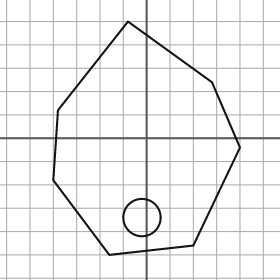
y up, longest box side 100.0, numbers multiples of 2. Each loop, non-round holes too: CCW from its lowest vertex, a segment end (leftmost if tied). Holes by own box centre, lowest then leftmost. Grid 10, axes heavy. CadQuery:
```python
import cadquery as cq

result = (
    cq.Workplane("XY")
    .moveTo(-16.0, -50.0)
    .lineTo(20.0, -46.0)
    .lineTo(40.0, -4.0)
    .lineTo(28.0, 24.0)
    .lineTo(-8.0, 50.0)
    .lineTo(-38.0, 12.0)
    .lineTo(-40.0, -18.0)
    .close()
    .moveTo(-2.0, -34.0)
    .circle(8.0)
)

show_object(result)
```